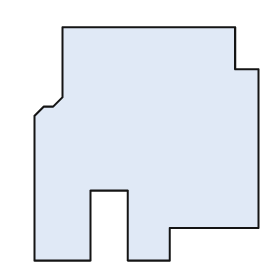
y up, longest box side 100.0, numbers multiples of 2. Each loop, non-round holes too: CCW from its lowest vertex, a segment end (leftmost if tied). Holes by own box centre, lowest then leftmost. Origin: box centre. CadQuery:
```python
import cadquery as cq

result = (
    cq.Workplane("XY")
    .moveTo(-48.0, -50.0)
    .lineTo(-24.0, -50.0)
    .lineTo(-24.0, -20.0)
    .lineTo(-8.0, -20.0)
    .lineTo(-8.0, -50.0)
    .lineTo(10.0, -50.0)
    .lineTo(10.0, -36.0)
    .lineTo(48.0, -36.0)
    .lineTo(48.0, 32.0)
    .lineTo(38.0, 32.0)
    .lineTo(38.0, 50.0)
    .lineTo(-36.0, 50.0)
    .lineTo(-36.0, 20.0)
    .lineTo(-40.0, 16.0)
    .lineTo(-44.0, 16.0)
    .lineTo(-48.0, 12.0)
    .close()
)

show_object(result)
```